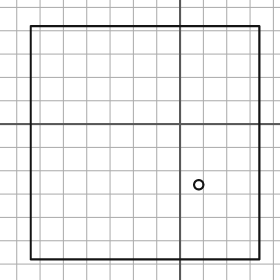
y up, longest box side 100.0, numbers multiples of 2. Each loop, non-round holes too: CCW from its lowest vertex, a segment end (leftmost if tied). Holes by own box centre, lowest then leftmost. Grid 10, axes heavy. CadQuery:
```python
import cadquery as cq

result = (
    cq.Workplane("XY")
    .moveTo(-64.0, -58.0)
    .lineTo(34.0, -58.0)
    .lineTo(34.0, 42.0)
    .lineTo(-64.0, 42.0)
    .close()
    .moveTo(8.0, -26.0)
    .circle(2.0)
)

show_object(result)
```